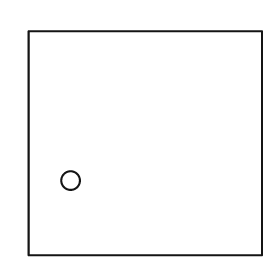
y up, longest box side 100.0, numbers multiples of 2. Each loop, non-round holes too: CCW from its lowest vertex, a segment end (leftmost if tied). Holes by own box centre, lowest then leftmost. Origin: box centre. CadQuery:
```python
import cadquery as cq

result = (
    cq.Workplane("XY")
    .moveTo(-50.0, -48.0)
    .lineTo(50.0, -48.0)
    .lineTo(50.0, 48.0)
    .lineTo(-50.0, 48.0)
    .close()
    .moveTo(-32.0, -16.0)
    .circle(4.0)
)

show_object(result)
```